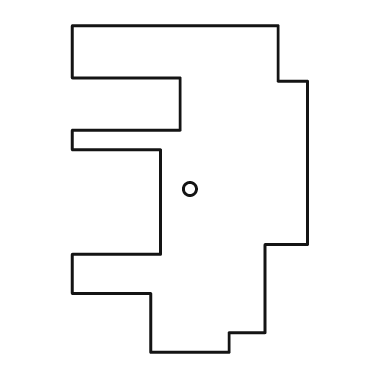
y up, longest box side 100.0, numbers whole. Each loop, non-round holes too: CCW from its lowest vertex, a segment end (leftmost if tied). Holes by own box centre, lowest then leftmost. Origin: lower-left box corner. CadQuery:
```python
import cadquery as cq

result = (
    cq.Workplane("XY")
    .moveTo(24.0, 0.0)
    .lineTo(48.0, 0.0)
    .lineTo(48.0, 6.0)
    .lineTo(59.0, 6.0)
    .lineTo(59.0, 33.0)
    .lineTo(72.0, 33.0)
    .lineTo(72.0, 83.0)
    .lineTo(63.0, 83.0)
    .lineTo(63.0, 100.0)
    .lineTo(0.0, 100.0)
    .lineTo(0.0, 84.0)
    .lineTo(33.0, 84.0)
    .lineTo(33.0, 68.0)
    .lineTo(0.0, 68.0)
    .lineTo(0.0, 62.0)
    .lineTo(27.0, 62.0)
    .lineTo(27.0, 30.0)
    .lineTo(0.0, 30.0)
    .lineTo(0.0, 18.0)
    .lineTo(24.0, 18.0)
    .close()
    .moveTo(36.0, 50.0)
    .circle(2.0)
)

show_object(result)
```